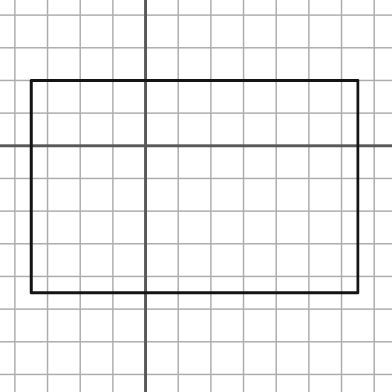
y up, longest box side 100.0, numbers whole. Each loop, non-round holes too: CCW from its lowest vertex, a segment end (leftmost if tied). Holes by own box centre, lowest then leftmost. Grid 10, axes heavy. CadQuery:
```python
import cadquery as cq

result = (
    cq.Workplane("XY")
    .moveTo(-35.0, -45.0)
    .lineTo(65.0, -45.0)
    .lineTo(65.0, 20.0)
    .lineTo(-35.0, 20.0)
    .close()
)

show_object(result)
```